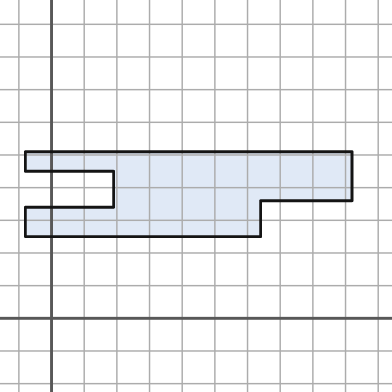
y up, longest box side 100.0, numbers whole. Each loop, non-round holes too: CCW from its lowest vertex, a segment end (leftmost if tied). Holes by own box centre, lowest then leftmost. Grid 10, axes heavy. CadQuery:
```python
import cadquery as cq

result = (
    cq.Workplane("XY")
    .moveTo(-8.0, 25.0)
    .lineTo(64.0, 25.0)
    .lineTo(64.0, 36.0)
    .lineTo(92.0, 36.0)
    .lineTo(92.0, 51.0)
    .lineTo(-8.0, 51.0)
    .lineTo(-8.0, 45.0)
    .lineTo(19.0, 45.0)
    .lineTo(19.0, 34.0)
    .lineTo(-8.0, 34.0)
    .close()
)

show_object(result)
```